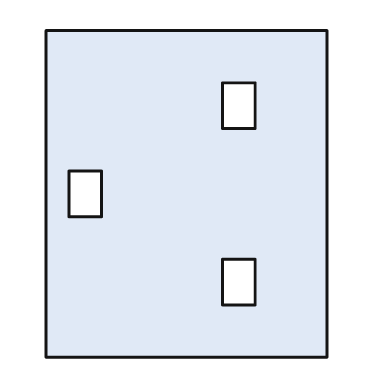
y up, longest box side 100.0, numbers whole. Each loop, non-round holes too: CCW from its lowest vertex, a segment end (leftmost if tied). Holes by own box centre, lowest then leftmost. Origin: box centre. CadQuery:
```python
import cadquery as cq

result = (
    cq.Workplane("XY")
    .moveTo(-43.0, -50.0)
    .lineTo(43.0, -50.0)
    .lineTo(43.0, 50.0)
    .lineTo(-43.0, 50.0)
    .close()
    .moveTo(11.0, -34.0)
    .lineTo(21.0, -34.0)
    .lineTo(21.0, -20.0)
    .lineTo(11.0, -20.0)
    .close()
    .moveTo(-36.0, -7.0)
    .lineTo(-26.0, -7.0)
    .lineTo(-26.0, 7.0)
    .lineTo(-36.0, 7.0)
    .close()
    .moveTo(11.0, 20.0)
    .lineTo(21.0, 20.0)
    .lineTo(21.0, 34.0)
    .lineTo(11.0, 34.0)
    .close()
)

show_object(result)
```